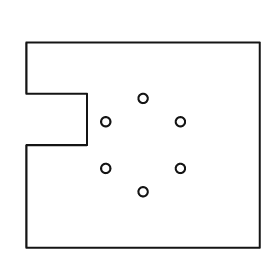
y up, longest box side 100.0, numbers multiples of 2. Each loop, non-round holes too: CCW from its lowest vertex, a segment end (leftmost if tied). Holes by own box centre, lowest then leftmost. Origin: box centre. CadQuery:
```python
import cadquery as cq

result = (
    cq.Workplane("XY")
    .moveTo(-50.0, -44.0)
    .lineTo(50.0, -44.0)
    .lineTo(50.0, 44.0)
    .lineTo(-50.0, 44.0)
    .lineTo(-50.0, 22.0)
    .lineTo(-24.0, 22.0)
    .lineTo(-24.0, 0.0)
    .lineTo(-50.0, 0.0)
    .close()
    .moveTo(0.0, -20.0)
    .circle(2.0)
    .moveTo(-16.0, -10.0)
    .circle(2.0)
    .moveTo(16.0, -10.0)
    .circle(2.0)
    .moveTo(-16.0, 10.0)
    .circle(2.0)
    .moveTo(16.0, 10.0)
    .circle(2.0)
    .moveTo(0.0, 20.0)
    .circle(2.0)
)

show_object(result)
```